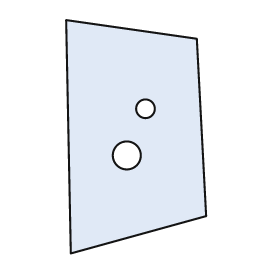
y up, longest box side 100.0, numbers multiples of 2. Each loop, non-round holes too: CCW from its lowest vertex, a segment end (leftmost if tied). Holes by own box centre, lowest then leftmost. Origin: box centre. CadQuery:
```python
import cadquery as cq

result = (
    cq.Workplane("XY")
    .moveTo(-28.0, -50.0)
    .lineTo(30.0, -34.0)
    .lineTo(26.0, 42.0)
    .lineTo(-30.0, 50.0)
    .close()
    .moveTo(-4.0, -8.0)
    .circle(6.0)
    .moveTo(4.0, 12.0)
    .circle(4.0)
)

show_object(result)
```